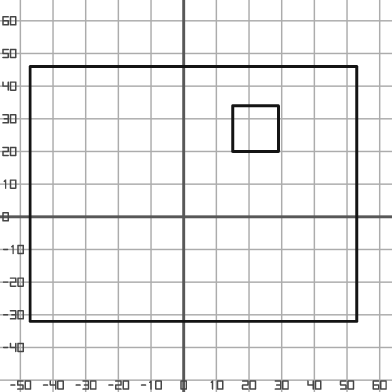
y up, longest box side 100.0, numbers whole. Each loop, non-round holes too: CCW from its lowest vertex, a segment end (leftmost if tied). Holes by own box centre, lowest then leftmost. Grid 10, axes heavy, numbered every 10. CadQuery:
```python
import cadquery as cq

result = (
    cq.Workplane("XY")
    .moveTo(-47.0, -32.0)
    .lineTo(53.0, -32.0)
    .lineTo(53.0, 46.0)
    .lineTo(-47.0, 46.0)
    .close()
    .moveTo(15.0, 20.0)
    .lineTo(29.0, 20.0)
    .lineTo(29.0, 34.0)
    .lineTo(15.0, 34.0)
    .close()
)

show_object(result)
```